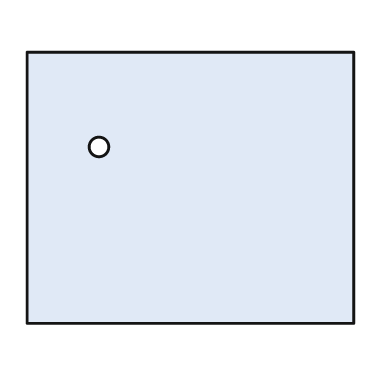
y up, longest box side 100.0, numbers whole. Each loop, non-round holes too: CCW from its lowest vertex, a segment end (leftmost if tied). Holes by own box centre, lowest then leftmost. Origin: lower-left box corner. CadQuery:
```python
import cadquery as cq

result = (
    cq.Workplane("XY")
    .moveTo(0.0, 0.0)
    .lineTo(100.0, 0.0)
    .lineTo(100.0, 83.0)
    .lineTo(0.0, 83.0)
    .close()
    .moveTo(22.0, 54.0)
    .circle(3.0)
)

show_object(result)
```